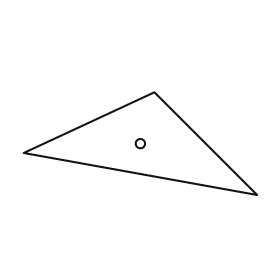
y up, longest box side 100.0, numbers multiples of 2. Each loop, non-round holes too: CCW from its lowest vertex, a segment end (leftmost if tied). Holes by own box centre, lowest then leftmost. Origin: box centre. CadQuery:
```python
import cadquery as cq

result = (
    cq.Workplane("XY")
    .moveTo(50.0, -22.0)
    .lineTo(6.0, 22.0)
    .lineTo(-50.0, -4.0)
    .close()
    .moveTo(0.0, 0.0)
    .circle(2.0)
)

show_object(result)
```